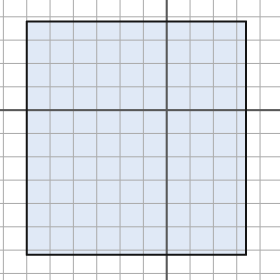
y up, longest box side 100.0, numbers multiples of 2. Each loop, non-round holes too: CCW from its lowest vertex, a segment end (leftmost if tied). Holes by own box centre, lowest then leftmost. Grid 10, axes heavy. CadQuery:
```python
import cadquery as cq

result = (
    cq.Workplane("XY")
    .moveTo(-60.0, -62.0)
    .lineTo(34.0, -62.0)
    .lineTo(34.0, 38.0)
    .lineTo(-60.0, 38.0)
    .close()
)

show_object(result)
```